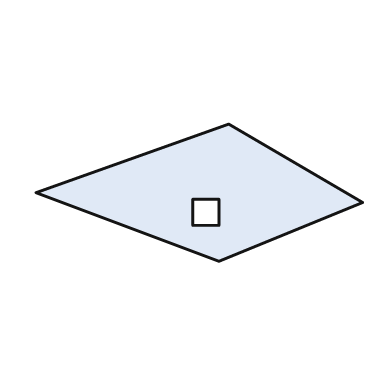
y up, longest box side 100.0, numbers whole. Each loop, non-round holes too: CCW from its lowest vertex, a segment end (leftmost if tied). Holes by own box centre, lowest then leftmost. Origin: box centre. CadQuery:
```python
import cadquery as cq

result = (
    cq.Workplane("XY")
    .moveTo(6.0, -21.0)
    .lineTo(50.0, -3.0)
    .lineTo(9.0, 21.0)
    .lineTo(-50.0, 0.0)
    .close()
    .moveTo(-2.0, -10.0)
    .lineTo(6.0, -10.0)
    .lineTo(6.0, -2.0)
    .lineTo(-2.0, -2.0)
    .close()
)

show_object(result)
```